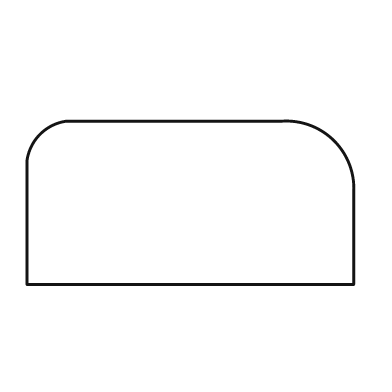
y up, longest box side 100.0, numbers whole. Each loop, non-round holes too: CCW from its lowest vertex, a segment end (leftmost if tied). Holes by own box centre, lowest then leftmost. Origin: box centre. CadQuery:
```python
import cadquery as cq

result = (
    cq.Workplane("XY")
    .moveTo(-50.0, -25.0)
    .lineTo(50.0, -25.0)
    .lineTo(50.0, 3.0)
    .threePointArc((44.0, 19.0), (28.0, 25.0))
    .lineTo(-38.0, 25.0)
    .threePointArc((-46.0, 21.0), (-50.0, 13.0))
    .close()
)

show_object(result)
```